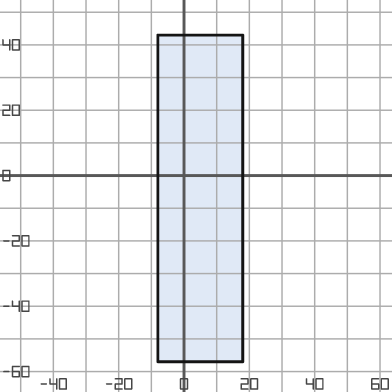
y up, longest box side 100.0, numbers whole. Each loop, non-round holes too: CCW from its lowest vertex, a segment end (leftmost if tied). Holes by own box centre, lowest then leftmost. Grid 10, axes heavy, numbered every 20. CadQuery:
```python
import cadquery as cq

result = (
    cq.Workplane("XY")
    .moveTo(-8.0, -57.0)
    .lineTo(18.0, -57.0)
    .lineTo(18.0, 43.0)
    .lineTo(-8.0, 43.0)
    .close()
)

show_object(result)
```